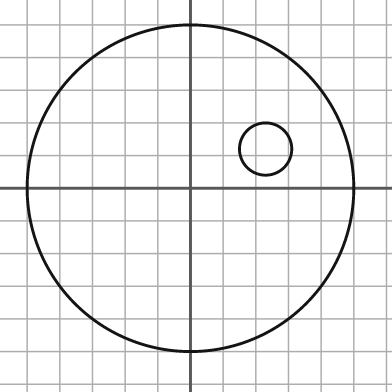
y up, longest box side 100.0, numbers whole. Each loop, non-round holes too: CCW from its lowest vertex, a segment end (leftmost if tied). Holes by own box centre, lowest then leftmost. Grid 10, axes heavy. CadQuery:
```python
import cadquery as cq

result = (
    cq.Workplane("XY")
    .moveTo(0.0, 0.0)
    .circle(50.0)
    .moveTo(23.0, 12.0)
    .circle(8.0)
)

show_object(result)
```